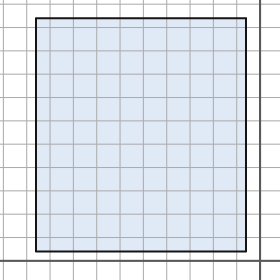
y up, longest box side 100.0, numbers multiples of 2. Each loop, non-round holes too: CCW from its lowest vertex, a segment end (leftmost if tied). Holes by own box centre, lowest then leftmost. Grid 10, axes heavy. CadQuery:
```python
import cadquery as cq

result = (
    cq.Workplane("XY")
    .moveTo(-96.0, 4.0)
    .lineTo(-6.0, 4.0)
    .lineTo(-6.0, 104.0)
    .lineTo(-96.0, 104.0)
    .close()
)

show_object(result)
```